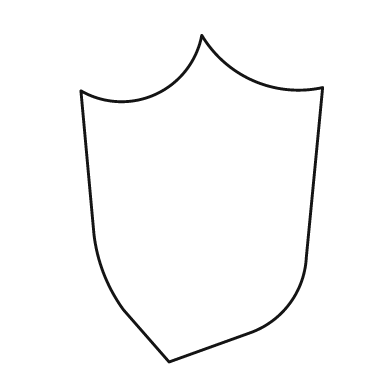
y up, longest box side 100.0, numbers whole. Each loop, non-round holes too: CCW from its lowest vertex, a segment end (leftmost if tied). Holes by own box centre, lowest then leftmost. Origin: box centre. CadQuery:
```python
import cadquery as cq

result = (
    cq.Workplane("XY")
    .moveTo(-10.0, -50.0)
    .lineTo(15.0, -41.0)
    .threePointArc((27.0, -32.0), (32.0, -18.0))
    .lineTo(37.0, 34.0)
    .threePointArc((16.0, 36.0), (0.0, 50.0))
    .threePointArc((-14.0, 32.0), (-37.0, 33.0))
    .lineTo(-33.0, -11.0)
    .threePointArc((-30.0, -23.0), (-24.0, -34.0))
    .close()
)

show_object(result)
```